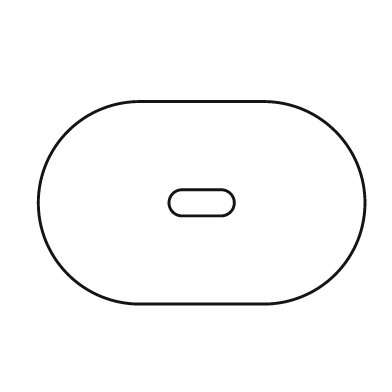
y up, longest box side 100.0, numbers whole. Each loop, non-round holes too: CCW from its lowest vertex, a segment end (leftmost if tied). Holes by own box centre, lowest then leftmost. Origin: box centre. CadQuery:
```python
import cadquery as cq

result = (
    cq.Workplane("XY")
    .moveTo(-19.0, -31.0)
    .lineTo(19.0, -31.0)
    .threePointArc((50.0, 0.0), (19.0, 31.0))
    .lineTo(-19.0, 31.0)
    .threePointArc((-50.0, 0.0), (-19.0, -31.0))
    .close()
    .moveTo(-6.0, -4.0)
    .lineTo(6.0, -4.0)
    .threePointArc((10.0, 0.0), (6.0, 4.0))
    .lineTo(-6.0, 4.0)
    .threePointArc((-10.0, 0.0), (-6.0, -4.0))
    .close()
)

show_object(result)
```